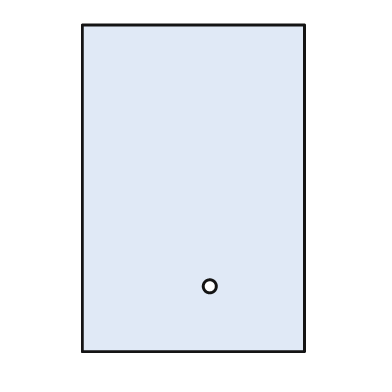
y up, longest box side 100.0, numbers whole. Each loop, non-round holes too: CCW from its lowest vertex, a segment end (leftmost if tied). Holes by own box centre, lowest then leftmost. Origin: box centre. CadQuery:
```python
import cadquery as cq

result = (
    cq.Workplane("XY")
    .moveTo(-34.0, -50.0)
    .lineTo(34.0, -50.0)
    .lineTo(34.0, 50.0)
    .lineTo(-34.0, 50.0)
    .close()
    .moveTo(5.0, -30.0)
    .circle(2.0)
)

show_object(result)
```